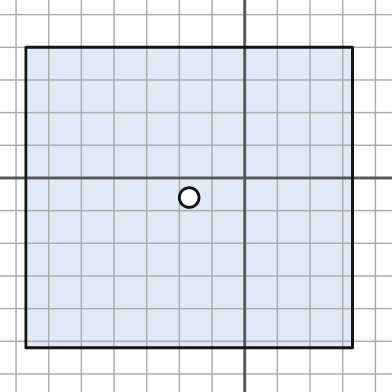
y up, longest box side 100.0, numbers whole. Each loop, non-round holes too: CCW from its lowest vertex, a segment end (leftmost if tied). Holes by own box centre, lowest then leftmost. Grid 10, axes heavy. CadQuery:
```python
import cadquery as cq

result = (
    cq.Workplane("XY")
    .moveTo(-67.0, -52.0)
    .lineTo(33.0, -52.0)
    .lineTo(33.0, 40.0)
    .lineTo(-67.0, 40.0)
    .close()
    .moveTo(-17.0, -6.0)
    .circle(3.0)
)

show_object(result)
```